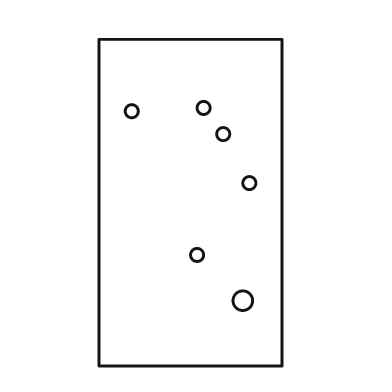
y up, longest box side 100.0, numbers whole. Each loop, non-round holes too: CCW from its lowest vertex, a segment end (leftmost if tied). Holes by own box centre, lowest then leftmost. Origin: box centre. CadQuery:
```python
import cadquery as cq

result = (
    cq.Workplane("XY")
    .moveTo(-28.0, -50.0)
    .lineTo(28.0, -50.0)
    .lineTo(28.0, 50.0)
    .lineTo(-28.0, 50.0)
    .close()
    .moveTo(16.0, -30.0)
    .circle(3.0)
    .moveTo(2.0, -16.0)
    .circle(2.0)
    .moveTo(18.0, 6.0)
    .circle(2.0)
    .moveTo(10.0, 21.0)
    .circle(2.0)
    .moveTo(-18.0, 28.0)
    .circle(2.0)
    .moveTo(4.0, 29.0)
    .circle(2.0)
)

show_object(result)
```